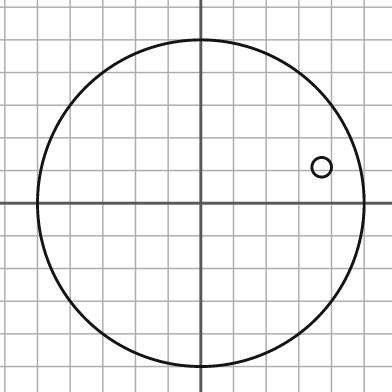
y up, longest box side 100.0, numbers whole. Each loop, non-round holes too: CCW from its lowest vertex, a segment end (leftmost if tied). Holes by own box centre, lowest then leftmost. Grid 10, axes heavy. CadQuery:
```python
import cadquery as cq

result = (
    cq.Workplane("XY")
    .moveTo(0.0, 0.0)
    .circle(50.0)
    .moveTo(37.0, 11.0)
    .circle(3.0)
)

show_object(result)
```